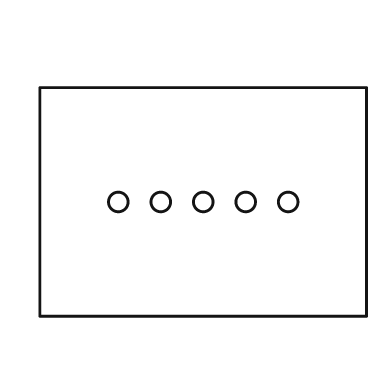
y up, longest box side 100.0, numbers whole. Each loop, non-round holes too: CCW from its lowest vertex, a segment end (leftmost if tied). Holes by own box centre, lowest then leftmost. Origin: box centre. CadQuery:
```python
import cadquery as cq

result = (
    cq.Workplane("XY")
    .moveTo(-50.0, -35.0)
    .lineTo(50.0, -35.0)
    .lineTo(50.0, 35.0)
    .lineTo(-50.0, 35.0)
    .close()
    .moveTo(-26.0, 0.0)
    .circle(3.0)
    .moveTo(-13.0, 0.0)
    .circle(3.0)
    .moveTo(0.0, 0.0)
    .circle(3.0)
    .moveTo(13.0, 0.0)
    .circle(3.0)
    .moveTo(26.0, 0.0)
    .circle(3.0)
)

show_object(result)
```